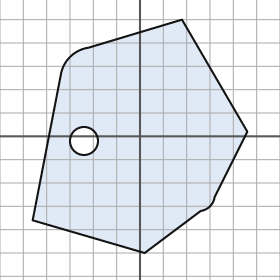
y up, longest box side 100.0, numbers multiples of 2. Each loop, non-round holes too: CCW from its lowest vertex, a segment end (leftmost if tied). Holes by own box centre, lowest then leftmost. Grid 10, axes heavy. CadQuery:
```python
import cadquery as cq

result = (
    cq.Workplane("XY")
    .moveTo(2.0, -50.0)
    .lineTo(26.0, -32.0)
    .threePointArc((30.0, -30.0), (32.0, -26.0))
    .lineTo(46.0, 2.0)
    .lineTo(18.0, 50.0)
    .lineTo(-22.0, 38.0)
    .threePointArc((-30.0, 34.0), (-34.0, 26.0))
    .lineTo(-46.0, -36.0)
    .close()
    .moveTo(-24.0, -2.0)
    .circle(6.0)
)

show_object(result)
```